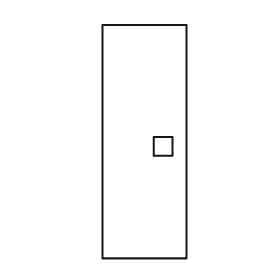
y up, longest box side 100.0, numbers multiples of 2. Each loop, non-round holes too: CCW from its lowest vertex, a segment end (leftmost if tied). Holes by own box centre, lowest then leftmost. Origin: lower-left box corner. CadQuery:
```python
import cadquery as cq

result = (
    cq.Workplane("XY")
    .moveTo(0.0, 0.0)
    .lineTo(36.0, 0.0)
    .lineTo(36.0, 100.0)
    .lineTo(0.0, 100.0)
    .close()
    .moveTo(22.0, 44.0)
    .lineTo(30.0, 44.0)
    .lineTo(30.0, 52.0)
    .lineTo(22.0, 52.0)
    .close()
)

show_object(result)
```